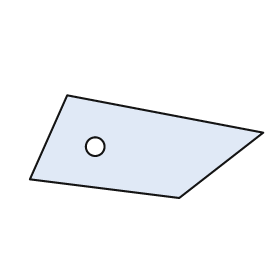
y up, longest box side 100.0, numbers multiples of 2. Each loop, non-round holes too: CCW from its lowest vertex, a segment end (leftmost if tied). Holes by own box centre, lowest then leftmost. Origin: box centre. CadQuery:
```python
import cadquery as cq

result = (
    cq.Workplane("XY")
    .moveTo(14.0, -22.0)
    .lineTo(50.0, 6.0)
    .lineTo(-34.0, 22.0)
    .lineTo(-50.0, -14.0)
    .close()
    .moveTo(-22.0, 0.0)
    .circle(4.0)
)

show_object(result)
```